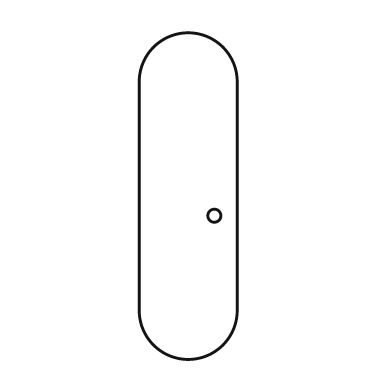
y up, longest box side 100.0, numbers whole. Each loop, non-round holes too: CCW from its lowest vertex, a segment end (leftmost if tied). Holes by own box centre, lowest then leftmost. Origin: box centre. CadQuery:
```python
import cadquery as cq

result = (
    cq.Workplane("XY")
    .moveTo(-15.0, -35.0)
    .threePointArc((0.0, -50.0), (15.0, -35.0))
    .lineTo(15.0, 35.0)
    .threePointArc((0.0, 50.0), (-15.0, 35.0))
    .close()
    .moveTo(8.0, -6.0)
    .circle(2.0)
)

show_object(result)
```